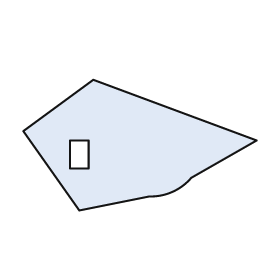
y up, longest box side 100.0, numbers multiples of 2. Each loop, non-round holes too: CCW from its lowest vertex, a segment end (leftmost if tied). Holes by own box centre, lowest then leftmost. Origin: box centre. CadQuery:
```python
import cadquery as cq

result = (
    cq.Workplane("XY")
    .moveTo(-26.0, -28.0)
    .lineTo(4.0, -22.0)
    .threePointArc((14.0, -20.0), (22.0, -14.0))
    .lineTo(50.0, 2.0)
    .lineTo(-20.0, 28.0)
    .lineTo(-50.0, 6.0)
    .close()
    .moveTo(-30.0, -10.0)
    .lineTo(-22.0, -10.0)
    .lineTo(-22.0, 2.0)
    .lineTo(-30.0, 2.0)
    .close()
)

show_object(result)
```